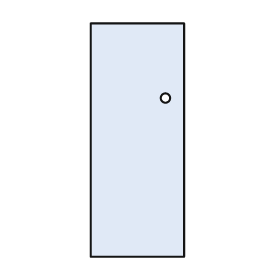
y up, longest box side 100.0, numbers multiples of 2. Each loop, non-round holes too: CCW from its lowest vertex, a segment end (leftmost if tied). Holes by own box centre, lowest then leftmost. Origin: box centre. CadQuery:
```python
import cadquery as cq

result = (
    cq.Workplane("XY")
    .moveTo(-20.0, -50.0)
    .lineTo(20.0, -50.0)
    .lineTo(20.0, 50.0)
    .lineTo(-20.0, 50.0)
    .close()
    .moveTo(12.0, 18.0)
    .circle(2.0)
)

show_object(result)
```